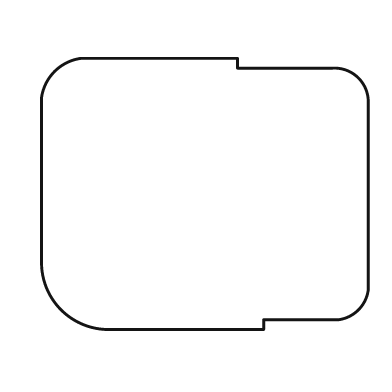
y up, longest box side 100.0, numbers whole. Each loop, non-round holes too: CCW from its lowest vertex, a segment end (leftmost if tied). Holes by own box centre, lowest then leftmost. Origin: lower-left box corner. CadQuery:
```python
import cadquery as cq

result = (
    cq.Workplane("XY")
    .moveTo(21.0, 0.0)
    .lineTo(68.0, 0.0)
    .lineTo(68.0, 3.0)
    .lineTo(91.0, 3.0)
    .threePointArc((97.0, 6.0), (100.0, 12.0))
    .lineTo(100.0, 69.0)
    .threePointArc((97.0, 77.0), (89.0, 80.0))
    .lineTo(60.0, 80.0)
    .lineTo(60.0, 83.0)
    .lineTo(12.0, 83.0)
    .threePointArc((4.0, 79.0), (0.0, 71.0))
    .lineTo(0.0, 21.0)
    .threePointArc((6.0, 6.0), (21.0, 0.0))
    .close()
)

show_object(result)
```